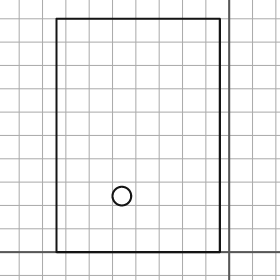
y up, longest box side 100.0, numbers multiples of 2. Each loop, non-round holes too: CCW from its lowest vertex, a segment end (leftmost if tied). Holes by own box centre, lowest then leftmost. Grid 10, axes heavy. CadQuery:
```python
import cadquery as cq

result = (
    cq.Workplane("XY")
    .moveTo(-74.0, 0.0)
    .lineTo(-4.0, 0.0)
    .lineTo(-4.0, 100.0)
    .lineTo(-74.0, 100.0)
    .close()
    .moveTo(-46.0, 24.0)
    .circle(4.0)
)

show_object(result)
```